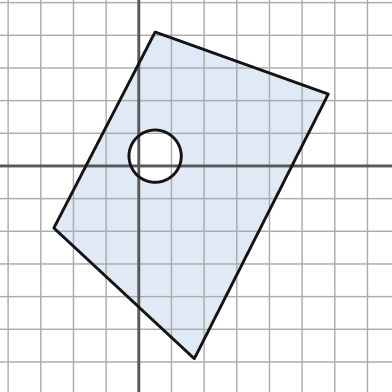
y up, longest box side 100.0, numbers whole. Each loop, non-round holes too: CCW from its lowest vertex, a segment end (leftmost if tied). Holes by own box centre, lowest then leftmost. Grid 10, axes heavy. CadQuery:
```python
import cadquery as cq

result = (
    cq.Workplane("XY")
    .moveTo(17.0, -59.0)
    .lineTo(58.0, 22.0)
    .lineTo(5.0, 41.0)
    .lineTo(-26.0, -19.0)
    .close()
    .moveTo(5.0, 3.0)
    .circle(8.0)
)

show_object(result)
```